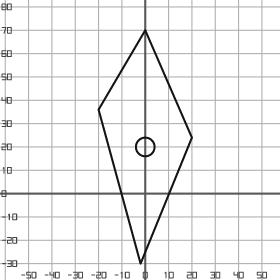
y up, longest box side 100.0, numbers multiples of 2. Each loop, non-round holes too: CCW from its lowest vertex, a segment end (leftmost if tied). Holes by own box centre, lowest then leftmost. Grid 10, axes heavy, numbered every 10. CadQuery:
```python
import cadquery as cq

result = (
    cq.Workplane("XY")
    .moveTo(-2.0, -30.0)
    .lineTo(20.0, 24.0)
    .lineTo(0.0, 70.0)
    .lineTo(-20.0, 36.0)
    .close()
    .moveTo(0.0, 20.0)
    .circle(4.0)
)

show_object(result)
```